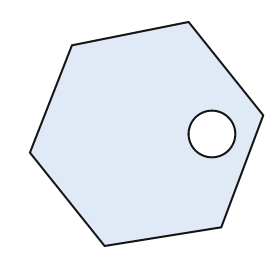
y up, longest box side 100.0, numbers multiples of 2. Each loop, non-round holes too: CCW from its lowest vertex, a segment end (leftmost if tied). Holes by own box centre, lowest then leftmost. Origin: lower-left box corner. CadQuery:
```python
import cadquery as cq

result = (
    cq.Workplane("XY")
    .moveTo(32.0, 0.0)
    .lineTo(82.0, 8.0)
    .lineTo(100.0, 56.0)
    .lineTo(68.0, 96.0)
    .lineTo(18.0, 86.0)
    .lineTo(0.0, 40.0)
    .close()
    .moveTo(78.0, 48.0)
    .circle(10.0)
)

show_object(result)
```